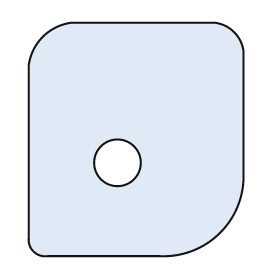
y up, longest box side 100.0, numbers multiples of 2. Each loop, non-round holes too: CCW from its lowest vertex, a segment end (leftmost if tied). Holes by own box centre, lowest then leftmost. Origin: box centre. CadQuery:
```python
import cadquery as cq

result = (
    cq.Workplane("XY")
    .moveTo(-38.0, -50.0)
    .lineTo(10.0, -50.0)
    .threePointArc((36.0, -40.0), (46.0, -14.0))
    .lineTo(46.0, 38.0)
    .threePointArc((42.0, 46.0), (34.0, 50.0))
    .lineTo(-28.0, 50.0)
    .threePointArc((-40.0, 44.0), (-46.0, 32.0))
    .lineTo(-46.0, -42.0)
    .threePointArc((-44.0, -48.0), (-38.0, -50.0))
    .close()
    .moveTo(-8.0, -10.0)
    .circle(10.0)
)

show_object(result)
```